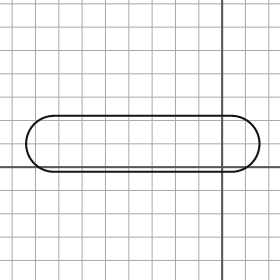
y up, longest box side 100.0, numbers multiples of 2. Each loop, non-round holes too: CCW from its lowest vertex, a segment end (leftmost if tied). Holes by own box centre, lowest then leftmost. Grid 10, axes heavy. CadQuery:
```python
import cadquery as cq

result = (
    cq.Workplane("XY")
    .moveTo(-72.0, -2.0)
    .lineTo(4.0, -2.0)
    .threePointArc((16.0, 10.0), (4.0, 22.0))
    .lineTo(-72.0, 22.0)
    .threePointArc((-84.0, 10.0), (-72.0, -2.0))
    .close()
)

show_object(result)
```